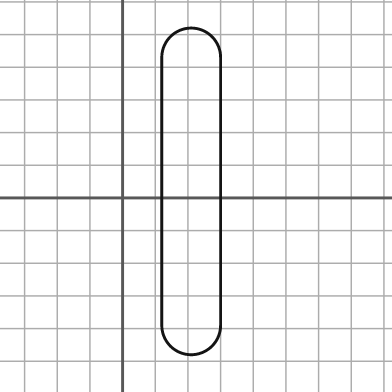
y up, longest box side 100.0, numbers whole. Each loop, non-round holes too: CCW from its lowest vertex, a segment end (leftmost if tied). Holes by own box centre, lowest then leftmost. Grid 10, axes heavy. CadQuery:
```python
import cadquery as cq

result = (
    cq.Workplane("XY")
    .moveTo(12.0, -39.0)
    .threePointArc((21.0, -48.0), (30.0, -39.0))
    .lineTo(30.0, 43.0)
    .threePointArc((21.0, 52.0), (12.0, 43.0))
    .close()
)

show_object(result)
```